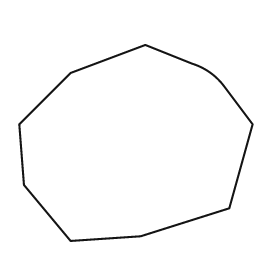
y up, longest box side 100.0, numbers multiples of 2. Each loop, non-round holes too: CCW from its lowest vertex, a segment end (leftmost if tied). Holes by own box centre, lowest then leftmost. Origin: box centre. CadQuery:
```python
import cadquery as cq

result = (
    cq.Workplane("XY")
    .moveTo(-28.0, -42.0)
    .lineTo(2.0, -40.0)
    .lineTo(40.0, -28.0)
    .lineTo(50.0, 8.0)
    .lineTo(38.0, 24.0)
    .threePointArc((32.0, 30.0), (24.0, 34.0))
    .lineTo(4.0, 42.0)
    .lineTo(-28.0, 30.0)
    .lineTo(-50.0, 8.0)
    .lineTo(-48.0, -18.0)
    .close()
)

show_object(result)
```